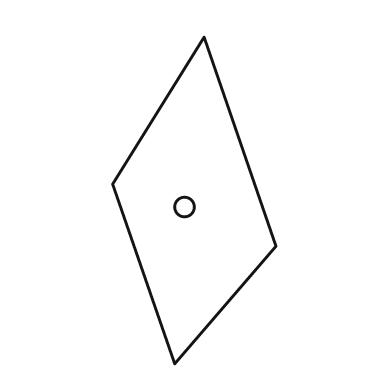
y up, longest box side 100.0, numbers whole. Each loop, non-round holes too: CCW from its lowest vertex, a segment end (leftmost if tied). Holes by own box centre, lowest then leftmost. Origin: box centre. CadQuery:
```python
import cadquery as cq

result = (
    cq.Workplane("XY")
    .moveTo(-6.0, -50.0)
    .lineTo(25.0, -14.0)
    .lineTo(3.0, 50.0)
    .lineTo(-25.0, 5.0)
    .close()
    .moveTo(-3.0, -2.0)
    .circle(3.0)
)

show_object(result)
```